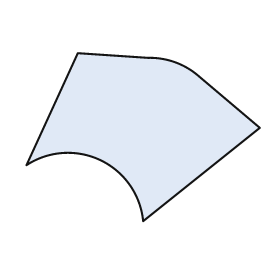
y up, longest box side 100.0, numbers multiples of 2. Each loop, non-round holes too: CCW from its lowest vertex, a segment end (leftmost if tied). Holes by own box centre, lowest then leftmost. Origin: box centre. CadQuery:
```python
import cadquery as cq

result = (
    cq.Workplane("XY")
    .moveTo(0.0, -36.0)
    .lineTo(50.0, 4.0)
    .lineTo(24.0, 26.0)
    .threePointArc((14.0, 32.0), (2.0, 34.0))
    .lineTo(-28.0, 36.0)
    .lineTo(-50.0, -12.0)
    .threePointArc((-18.0, -10.0), (0.0, -36.0))
    .close()
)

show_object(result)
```